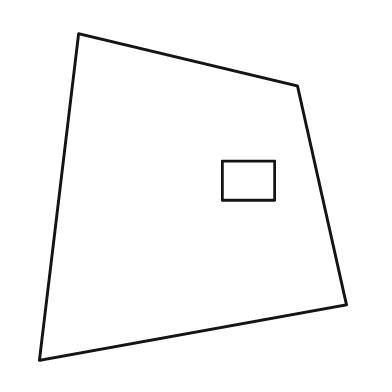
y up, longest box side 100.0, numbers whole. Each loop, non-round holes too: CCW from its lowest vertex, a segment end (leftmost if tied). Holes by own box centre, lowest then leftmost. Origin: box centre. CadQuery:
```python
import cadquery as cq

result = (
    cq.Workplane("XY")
    .moveTo(-47.0, -50.0)
    .lineTo(47.0, -33.0)
    .lineTo(32.0, 34.0)
    .lineTo(-35.0, 50.0)
    .close()
    .moveTo(9.0, -1.0)
    .lineTo(25.0, -1.0)
    .lineTo(25.0, 11.0)
    .lineTo(9.0, 11.0)
    .close()
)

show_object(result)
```